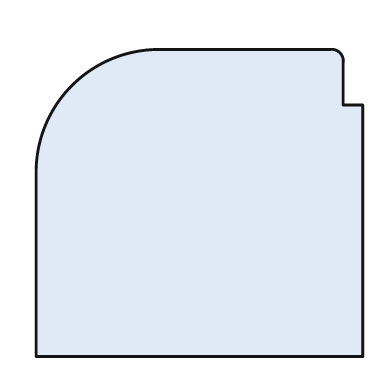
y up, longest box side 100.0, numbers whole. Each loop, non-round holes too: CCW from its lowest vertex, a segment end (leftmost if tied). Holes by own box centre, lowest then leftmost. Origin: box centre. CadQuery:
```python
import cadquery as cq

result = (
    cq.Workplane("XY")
    .moveTo(-50.0, -47.0)
    .lineTo(50.0, -47.0)
    .lineTo(50.0, 30.0)
    .lineTo(44.0, 30.0)
    .lineTo(44.0, 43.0)
    .threePointArc((43.0, 46.0), (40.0, 47.0))
    .lineTo(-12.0, 47.0)
    .threePointArc((-39.0, 36.0), (-50.0, 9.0))
    .close()
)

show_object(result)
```